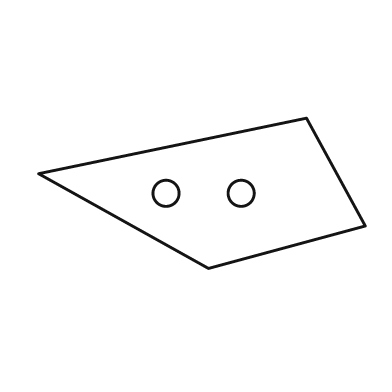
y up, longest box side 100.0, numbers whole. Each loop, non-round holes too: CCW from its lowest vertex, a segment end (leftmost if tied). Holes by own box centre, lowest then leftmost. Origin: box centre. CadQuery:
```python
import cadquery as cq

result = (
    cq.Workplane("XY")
    .moveTo(2.0, -23.0)
    .lineTo(50.0, -10.0)
    .lineTo(32.0, 23.0)
    .lineTo(-50.0, 6.0)
    .close()
    .moveTo(-11.0, 0.0)
    .circle(4.0)
    .moveTo(12.0, 0.0)
    .circle(4.0)
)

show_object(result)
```